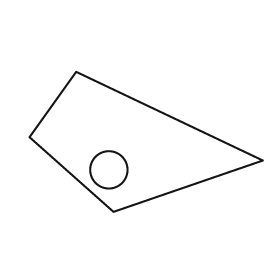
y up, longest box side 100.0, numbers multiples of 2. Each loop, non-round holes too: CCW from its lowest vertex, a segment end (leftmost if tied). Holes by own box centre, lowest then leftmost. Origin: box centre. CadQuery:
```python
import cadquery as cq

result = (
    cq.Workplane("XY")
    .moveTo(-14.0, -30.0)
    .lineTo(50.0, -8.0)
    .lineTo(-30.0, 30.0)
    .lineTo(-50.0, 2.0)
    .close()
    .moveTo(-16.0, -12.0)
    .circle(8.0)
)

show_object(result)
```